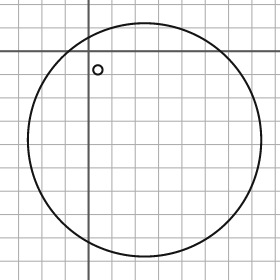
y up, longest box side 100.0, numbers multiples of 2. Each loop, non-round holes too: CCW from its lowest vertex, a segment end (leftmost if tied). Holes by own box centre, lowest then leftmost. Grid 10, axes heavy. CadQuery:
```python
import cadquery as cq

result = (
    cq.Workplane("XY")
    .moveTo(24.0, -38.0)
    .circle(50.0)
    .moveTo(4.0, -8.0)
    .circle(2.0)
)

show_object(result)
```